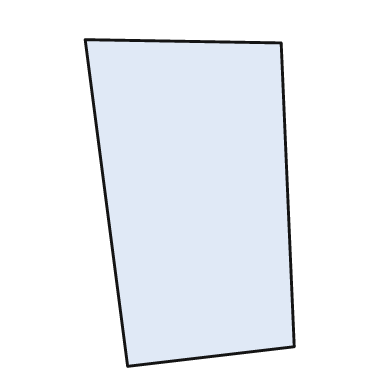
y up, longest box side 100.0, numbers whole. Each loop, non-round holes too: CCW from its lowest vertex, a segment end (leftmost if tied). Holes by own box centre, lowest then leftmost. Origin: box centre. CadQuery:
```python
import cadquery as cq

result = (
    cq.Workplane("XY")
    .moveTo(-19.0, -50.0)
    .lineTo(32.0, -44.0)
    .lineTo(28.0, 49.0)
    .lineTo(-32.0, 50.0)
    .close()
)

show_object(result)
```